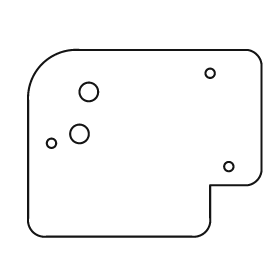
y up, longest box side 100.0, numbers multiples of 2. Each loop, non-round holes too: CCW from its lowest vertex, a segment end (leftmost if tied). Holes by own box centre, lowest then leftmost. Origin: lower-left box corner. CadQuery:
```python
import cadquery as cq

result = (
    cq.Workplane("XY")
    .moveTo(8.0, 0.0)
    .lineTo(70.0, 0.0)
    .threePointArc((76.0, 2.0), (78.0, 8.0))
    .lineTo(78.0, 22.0)
    .lineTo(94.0, 22.0)
    .threePointArc((98.0, 24.0), (100.0, 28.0))
    .lineTo(100.0, 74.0)
    .threePointArc((98.0, 78.0), (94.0, 80.0))
    .lineTo(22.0, 80.0)
    .threePointArc((6.0, 74.0), (0.0, 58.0))
    .lineTo(0.0, 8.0)
    .threePointArc((2.0, 2.0), (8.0, 0.0))
    .close()
    .moveTo(86.0, 30.0)
    .circle(2.0)
    .moveTo(10.0, 40.0)
    .circle(2.0)
    .moveTo(22.0, 44.0)
    .circle(4.0)
    .moveTo(26.0, 62.0)
    .circle(4.0)
    .moveTo(78.0, 70.0)
    .circle(2.0)
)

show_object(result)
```